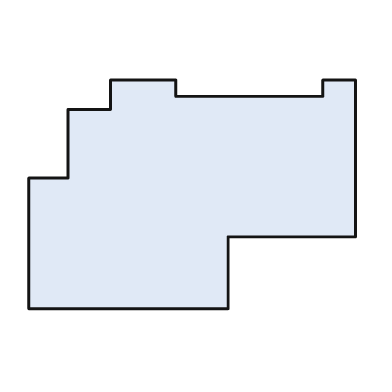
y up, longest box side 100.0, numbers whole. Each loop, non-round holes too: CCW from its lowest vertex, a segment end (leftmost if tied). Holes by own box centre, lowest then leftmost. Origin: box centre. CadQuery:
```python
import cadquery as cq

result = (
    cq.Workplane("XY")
    .moveTo(-50.0, -35.0)
    .lineTo(11.0, -35.0)
    .lineTo(11.0, -13.0)
    .lineTo(50.0, -13.0)
    .lineTo(50.0, 35.0)
    .lineTo(40.0, 35.0)
    .lineTo(40.0, 30.0)
    .lineTo(-5.0, 30.0)
    .lineTo(-5.0, 35.0)
    .lineTo(-25.0, 35.0)
    .lineTo(-25.0, 26.0)
    .lineTo(-38.0, 26.0)
    .lineTo(-38.0, 5.0)
    .lineTo(-50.0, 5.0)
    .close()
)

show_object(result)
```